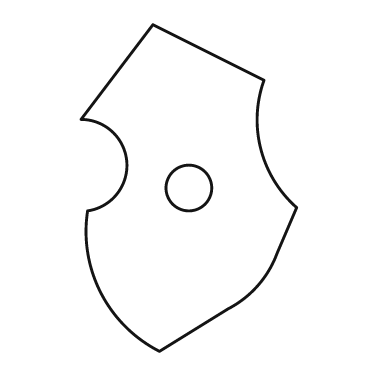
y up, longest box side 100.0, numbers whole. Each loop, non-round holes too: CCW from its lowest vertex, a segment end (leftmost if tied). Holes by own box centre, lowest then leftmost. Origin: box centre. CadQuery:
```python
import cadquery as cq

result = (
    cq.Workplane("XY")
    .moveTo(-9.0, -50.0)
    .lineTo(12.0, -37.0)
    .threePointArc((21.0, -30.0), (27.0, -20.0))
    .lineTo(33.0, -6.0)
    .threePointArc((22.0, 12.0), (23.0, 33.0))
    .lineTo(-11.0, 50.0)
    .lineTo(-33.0, 21.0)
    .threePointArc((-19.0, 8.0), (-31.0, -7.0))
    .threePointArc((-27.0, -32.0), (-9.0, -50.0))
    .close()
    .moveTo(0.0, 0.0)
    .circle(7.0)
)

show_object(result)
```